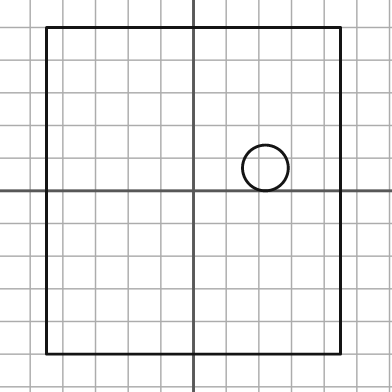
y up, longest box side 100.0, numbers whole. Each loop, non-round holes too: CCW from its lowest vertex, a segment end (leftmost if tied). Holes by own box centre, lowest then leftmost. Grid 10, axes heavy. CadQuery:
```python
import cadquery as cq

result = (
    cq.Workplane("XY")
    .moveTo(-45.0, -50.0)
    .lineTo(45.0, -50.0)
    .lineTo(45.0, 50.0)
    .lineTo(-45.0, 50.0)
    .close()
    .moveTo(22.0, 7.0)
    .circle(7.0)
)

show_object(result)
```